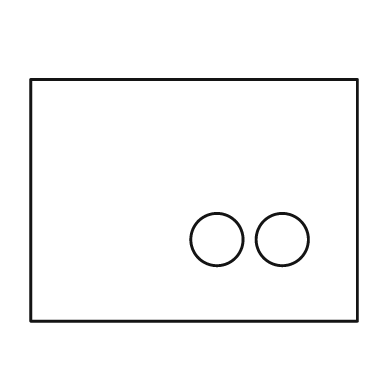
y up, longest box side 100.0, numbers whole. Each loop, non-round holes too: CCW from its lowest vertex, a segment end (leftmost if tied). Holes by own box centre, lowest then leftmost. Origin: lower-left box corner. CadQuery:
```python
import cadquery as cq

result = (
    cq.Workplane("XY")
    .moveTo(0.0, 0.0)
    .lineTo(100.0, 0.0)
    .lineTo(100.0, 74.0)
    .lineTo(0.0, 74.0)
    .close()
    .moveTo(57.0, 25.0)
    .circle(8.0)
    .moveTo(77.0, 25.0)
    .circle(8.0)
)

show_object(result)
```